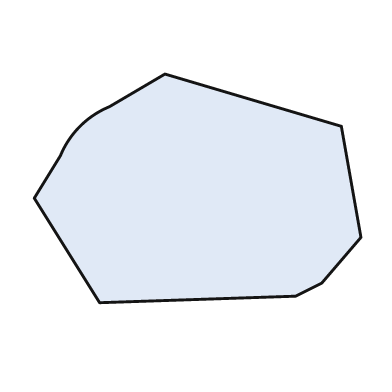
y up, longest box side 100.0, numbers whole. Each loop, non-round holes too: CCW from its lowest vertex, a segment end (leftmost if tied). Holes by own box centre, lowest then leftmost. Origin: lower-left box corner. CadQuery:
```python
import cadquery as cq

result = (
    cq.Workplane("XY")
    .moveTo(20.0, 0.0)
    .lineTo(80.0, 2.0)
    .lineTo(88.0, 6.0)
    .lineTo(100.0, 20.0)
    .lineTo(94.0, 54.0)
    .lineTo(40.0, 70.0)
    .lineTo(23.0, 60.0)
    .threePointArc((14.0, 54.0), (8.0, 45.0))
    .lineTo(0.0, 32.0)
    .close()
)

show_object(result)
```